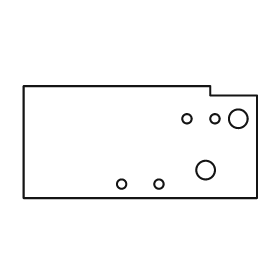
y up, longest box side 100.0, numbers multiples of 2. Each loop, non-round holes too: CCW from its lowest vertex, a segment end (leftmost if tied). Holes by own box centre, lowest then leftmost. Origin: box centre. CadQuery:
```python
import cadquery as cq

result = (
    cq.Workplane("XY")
    .moveTo(-50.0, -24.0)
    .lineTo(50.0, -24.0)
    .lineTo(50.0, 20.0)
    .lineTo(30.0, 20.0)
    .lineTo(30.0, 24.0)
    .lineTo(-50.0, 24.0)
    .close()
    .moveTo(-8.0, -18.0)
    .circle(2.0)
    .moveTo(8.0, -18.0)
    .circle(2.0)
    .moveTo(28.0, -12.0)
    .circle(4.0)
    .moveTo(20.0, 10.0)
    .circle(2.0)
    .moveTo(32.0, 10.0)
    .circle(2.0)
    .moveTo(42.0, 10.0)
    .circle(4.0)
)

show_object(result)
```